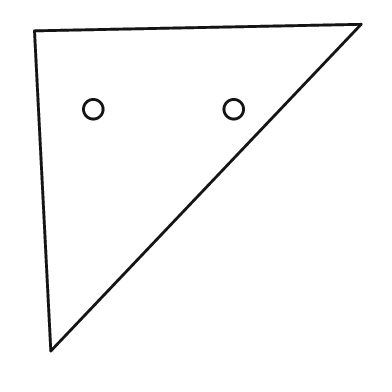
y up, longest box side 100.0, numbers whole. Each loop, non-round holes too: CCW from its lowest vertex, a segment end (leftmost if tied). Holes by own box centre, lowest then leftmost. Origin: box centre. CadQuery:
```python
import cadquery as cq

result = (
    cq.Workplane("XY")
    .moveTo(-45.0, -50.0)
    .lineTo(50.0, 50.0)
    .lineTo(-50.0, 48.0)
    .close()
    .moveTo(-32.0, 24.0)
    .circle(3.0)
    .moveTo(11.0, 24.0)
    .circle(3.0)
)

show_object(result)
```